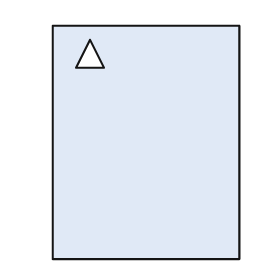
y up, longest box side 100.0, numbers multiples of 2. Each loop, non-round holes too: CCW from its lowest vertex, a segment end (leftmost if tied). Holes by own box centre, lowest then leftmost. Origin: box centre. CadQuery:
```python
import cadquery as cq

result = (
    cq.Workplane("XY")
    .moveTo(-40.0, -50.0)
    .lineTo(40.0, -50.0)
    .lineTo(40.0, 50.0)
    .lineTo(-40.0, 50.0)
    .close()
    .moveTo(-30.0, 32.0)
    .lineTo(-18.0, 32.0)
    .lineTo(-24.0, 44.0)
    .close()
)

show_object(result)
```